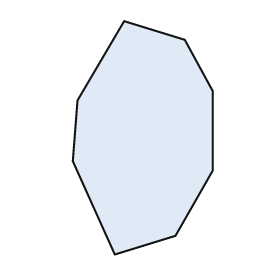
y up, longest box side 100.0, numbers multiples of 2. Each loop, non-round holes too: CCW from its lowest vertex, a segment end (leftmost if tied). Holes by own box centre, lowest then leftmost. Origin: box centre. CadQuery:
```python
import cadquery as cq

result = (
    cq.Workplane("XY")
    .moveTo(-12.0, -50.0)
    .lineTo(14.0, -42.0)
    .lineTo(30.0, -14.0)
    .lineTo(30.0, 20.0)
    .lineTo(18.0, 42.0)
    .lineTo(-8.0, 50.0)
    .lineTo(-28.0, 16.0)
    .lineTo(-30.0, -10.0)
    .close()
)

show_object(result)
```